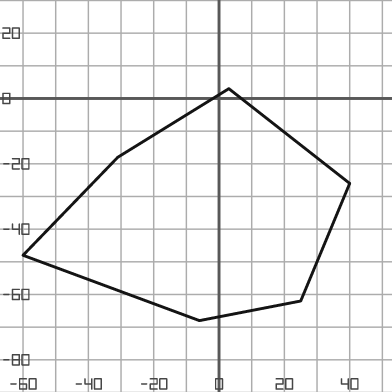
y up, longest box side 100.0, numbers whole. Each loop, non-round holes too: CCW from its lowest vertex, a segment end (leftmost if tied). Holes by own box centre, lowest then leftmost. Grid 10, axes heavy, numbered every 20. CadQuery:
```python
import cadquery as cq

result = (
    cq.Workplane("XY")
    .moveTo(-6.0, -68.0)
    .lineTo(25.0, -62.0)
    .lineTo(40.0, -26.0)
    .lineTo(3.0, 3.0)
    .lineTo(-31.0, -18.0)
    .lineTo(-60.0, -48.0)
    .close()
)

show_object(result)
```